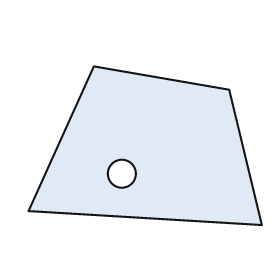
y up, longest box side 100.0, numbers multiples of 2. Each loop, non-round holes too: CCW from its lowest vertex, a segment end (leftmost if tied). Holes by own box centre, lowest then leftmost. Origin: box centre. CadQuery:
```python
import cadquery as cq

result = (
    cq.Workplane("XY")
    .moveTo(50.0, -34.0)
    .lineTo(36.0, 24.0)
    .lineTo(-22.0, 34.0)
    .lineTo(-50.0, -28.0)
    .close()
    .moveTo(-10.0, -12.0)
    .circle(6.0)
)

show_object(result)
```